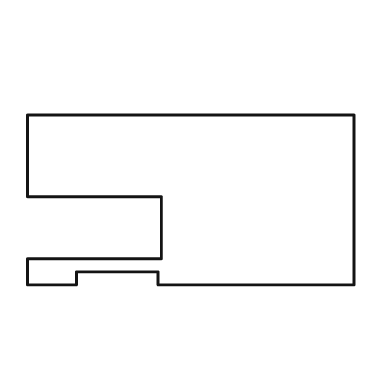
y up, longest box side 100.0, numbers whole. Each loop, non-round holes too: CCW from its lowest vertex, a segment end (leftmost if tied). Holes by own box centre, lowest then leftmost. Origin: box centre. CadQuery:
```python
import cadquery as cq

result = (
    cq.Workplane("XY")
    .moveTo(-50.0, -26.0)
    .lineTo(-35.0, -26.0)
    .lineTo(-35.0, -22.0)
    .lineTo(-10.0, -22.0)
    .lineTo(-10.0, -26.0)
    .lineTo(50.0, -26.0)
    .lineTo(50.0, 26.0)
    .lineTo(-50.0, 26.0)
    .lineTo(-50.0, 1.0)
    .lineTo(-9.0, 1.0)
    .lineTo(-9.0, -18.0)
    .lineTo(-50.0, -18.0)
    .close()
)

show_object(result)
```